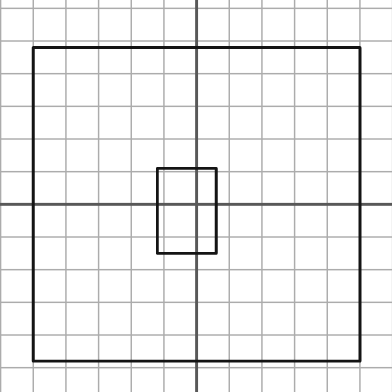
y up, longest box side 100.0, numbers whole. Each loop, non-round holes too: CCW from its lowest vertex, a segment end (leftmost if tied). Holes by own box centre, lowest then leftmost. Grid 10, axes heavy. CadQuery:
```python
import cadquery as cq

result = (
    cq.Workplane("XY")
    .moveTo(-50.0, -48.0)
    .lineTo(50.0, -48.0)
    .lineTo(50.0, 48.0)
    .lineTo(-50.0, 48.0)
    .close()
    .moveTo(-12.0, -15.0)
    .lineTo(6.0, -15.0)
    .lineTo(6.0, 11.0)
    .lineTo(-12.0, 11.0)
    .close()
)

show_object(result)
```